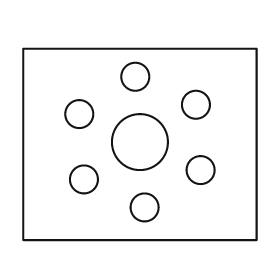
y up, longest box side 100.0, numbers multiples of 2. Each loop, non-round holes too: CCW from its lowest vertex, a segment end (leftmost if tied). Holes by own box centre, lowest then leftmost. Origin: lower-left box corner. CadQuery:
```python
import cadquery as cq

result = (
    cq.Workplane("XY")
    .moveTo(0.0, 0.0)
    .lineTo(100.0, 0.0)
    .lineTo(100.0, 82.0)
    .lineTo(0.0, 82.0)
    .close()
    .moveTo(52.0, 14.0)
    .circle(6.0)
    .moveTo(26.0, 26.0)
    .circle(6.0)
    .moveTo(76.0, 30.0)
    .circle(6.0)
    .moveTo(50.0, 42.0)
    .circle(12.0)
    .moveTo(24.0, 54.0)
    .circle(6.0)
    .moveTo(74.0, 58.0)
    .circle(6.0)
    .moveTo(48.0, 70.0)
    .circle(6.0)
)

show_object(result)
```